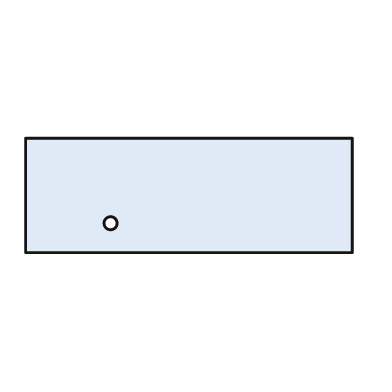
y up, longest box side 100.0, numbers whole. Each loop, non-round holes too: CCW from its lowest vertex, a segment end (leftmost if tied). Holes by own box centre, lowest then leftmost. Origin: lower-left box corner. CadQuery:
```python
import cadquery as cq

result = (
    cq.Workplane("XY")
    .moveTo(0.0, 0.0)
    .lineTo(100.0, 0.0)
    .lineTo(100.0, 35.0)
    .lineTo(0.0, 35.0)
    .close()
    .moveTo(26.0, 9.0)
    .circle(2.0)
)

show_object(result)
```